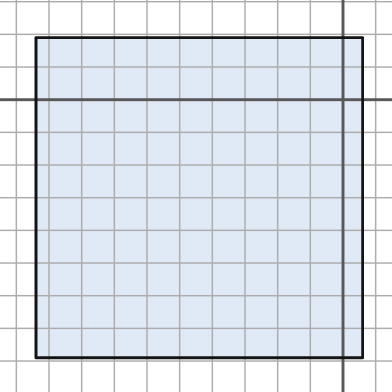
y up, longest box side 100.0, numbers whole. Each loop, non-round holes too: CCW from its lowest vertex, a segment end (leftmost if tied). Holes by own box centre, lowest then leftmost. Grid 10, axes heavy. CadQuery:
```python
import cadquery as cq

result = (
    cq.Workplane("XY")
    .moveTo(-94.0, -79.0)
    .lineTo(6.0, -79.0)
    .lineTo(6.0, 19.0)
    .lineTo(-94.0, 19.0)
    .close()
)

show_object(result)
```